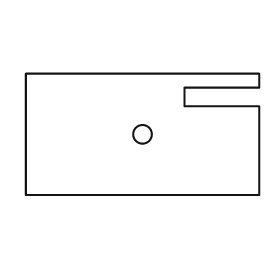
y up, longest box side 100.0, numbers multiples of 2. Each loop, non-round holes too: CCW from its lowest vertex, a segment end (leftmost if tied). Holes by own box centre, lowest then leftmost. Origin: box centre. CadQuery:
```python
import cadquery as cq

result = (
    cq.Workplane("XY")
    .moveTo(-50.0, -26.0)
    .lineTo(50.0, -26.0)
    .lineTo(50.0, 12.0)
    .lineTo(18.0, 12.0)
    .lineTo(18.0, 20.0)
    .lineTo(50.0, 20.0)
    .lineTo(50.0, 26.0)
    .lineTo(-50.0, 26.0)
    .close()
    .moveTo(0.0, 0.0)
    .circle(4.0)
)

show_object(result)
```